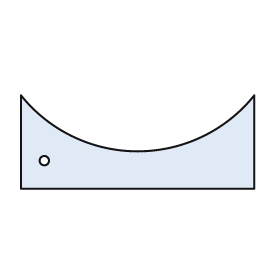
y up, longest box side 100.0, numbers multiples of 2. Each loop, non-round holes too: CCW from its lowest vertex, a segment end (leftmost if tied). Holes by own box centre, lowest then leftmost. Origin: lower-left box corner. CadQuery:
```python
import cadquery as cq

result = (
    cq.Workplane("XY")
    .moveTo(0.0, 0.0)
    .lineTo(100.0, 0.0)
    .lineTo(100.0, 40.0)
    .threePointArc((50.0, 16.0), (0.0, 40.0))
    .close()
    .moveTo(10.0, 12.0)
    .circle(2.0)
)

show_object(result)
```